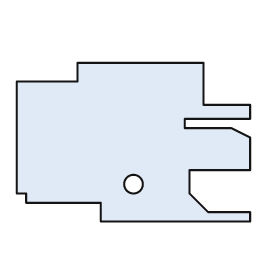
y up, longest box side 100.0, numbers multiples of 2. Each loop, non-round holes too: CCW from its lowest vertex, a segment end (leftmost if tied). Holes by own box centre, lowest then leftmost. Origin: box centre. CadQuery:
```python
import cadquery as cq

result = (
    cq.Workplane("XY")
    .moveTo(-14.0, -34.0)
    .lineTo(50.0, -34.0)
    .lineTo(50.0, -30.0)
    .lineTo(32.0, -30.0)
    .lineTo(24.0, -22.0)
    .lineTo(24.0, -12.0)
    .lineTo(50.0, -12.0)
    .lineTo(50.0, 2.0)
    .lineTo(42.0, 6.0)
    .lineTo(22.0, 6.0)
    .lineTo(22.0, 10.0)
    .lineTo(50.0, 10.0)
    .lineTo(50.0, 16.0)
    .lineTo(30.0, 16.0)
    .lineTo(30.0, 34.0)
    .lineTo(-24.0, 34.0)
    .lineTo(-24.0, 26.0)
    .lineTo(-50.0, 26.0)
    .lineTo(-50.0, -22.0)
    .lineTo(-46.0, -22.0)
    .lineTo(-46.0, -26.0)
    .lineTo(-14.0, -26.0)
    .close()
    .moveTo(0.0, -18.0)
    .circle(4.0)
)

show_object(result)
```